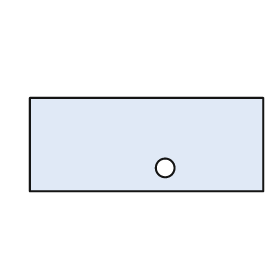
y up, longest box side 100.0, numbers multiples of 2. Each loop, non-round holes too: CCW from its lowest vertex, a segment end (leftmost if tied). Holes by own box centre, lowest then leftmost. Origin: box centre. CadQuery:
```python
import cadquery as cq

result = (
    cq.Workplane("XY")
    .moveTo(-50.0, -20.0)
    .lineTo(50.0, -20.0)
    .lineTo(50.0, 20.0)
    .lineTo(-50.0, 20.0)
    .close()
    .moveTo(8.0, -10.0)
    .circle(4.0)
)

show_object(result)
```